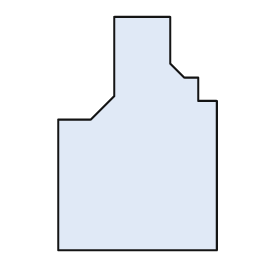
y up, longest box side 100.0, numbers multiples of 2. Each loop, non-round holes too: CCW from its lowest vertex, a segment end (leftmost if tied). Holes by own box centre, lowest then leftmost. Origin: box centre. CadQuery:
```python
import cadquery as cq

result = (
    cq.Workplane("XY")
    .moveTo(-34.0, -50.0)
    .lineTo(34.0, -50.0)
    .lineTo(34.0, 14.0)
    .lineTo(26.0, 14.0)
    .lineTo(26.0, 24.0)
    .lineTo(20.0, 24.0)
    .lineTo(14.0, 30.0)
    .lineTo(14.0, 50.0)
    .lineTo(-10.0, 50.0)
    .lineTo(-10.0, 16.0)
    .lineTo(-20.0, 6.0)
    .lineTo(-34.0, 6.0)
    .close()
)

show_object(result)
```